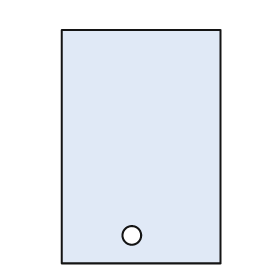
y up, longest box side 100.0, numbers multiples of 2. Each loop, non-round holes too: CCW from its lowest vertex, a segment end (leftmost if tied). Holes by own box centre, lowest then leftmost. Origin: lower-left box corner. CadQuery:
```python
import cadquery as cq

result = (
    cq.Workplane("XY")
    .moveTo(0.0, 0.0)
    .lineTo(68.0, 0.0)
    .lineTo(68.0, 100.0)
    .lineTo(0.0, 100.0)
    .close()
    .moveTo(30.0, 12.0)
    .circle(4.0)
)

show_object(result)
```